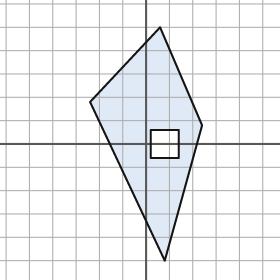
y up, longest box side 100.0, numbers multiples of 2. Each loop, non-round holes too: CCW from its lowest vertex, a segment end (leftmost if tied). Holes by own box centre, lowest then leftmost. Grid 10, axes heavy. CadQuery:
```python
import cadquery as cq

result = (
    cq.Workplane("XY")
    .moveTo(8.0, -50.0)
    .lineTo(24.0, 8.0)
    .lineTo(6.0, 50.0)
    .lineTo(-24.0, 18.0)
    .close()
    .moveTo(2.0, -6.0)
    .lineTo(14.0, -6.0)
    .lineTo(14.0, 6.0)
    .lineTo(2.0, 6.0)
    .close()
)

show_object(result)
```